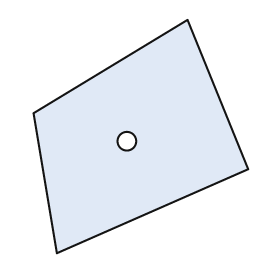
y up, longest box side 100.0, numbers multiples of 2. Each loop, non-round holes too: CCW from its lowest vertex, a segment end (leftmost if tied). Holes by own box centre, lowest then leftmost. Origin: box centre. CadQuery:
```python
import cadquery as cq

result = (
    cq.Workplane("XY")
    .moveTo(-36.0, -50.0)
    .lineTo(46.0, -14.0)
    .lineTo(20.0, 50.0)
    .lineTo(-46.0, 10.0)
    .close()
    .moveTo(-6.0, -2.0)
    .circle(4.0)
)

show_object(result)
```